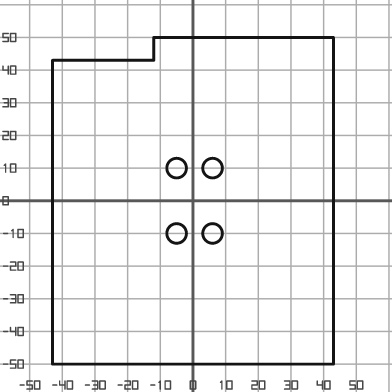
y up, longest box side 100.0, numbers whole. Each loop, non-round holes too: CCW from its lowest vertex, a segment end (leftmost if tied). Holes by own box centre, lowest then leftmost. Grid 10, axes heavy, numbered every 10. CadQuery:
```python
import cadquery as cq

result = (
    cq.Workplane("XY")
    .moveTo(-43.0, -50.0)
    .lineTo(43.0, -50.0)
    .lineTo(43.0, 50.0)
    .lineTo(-12.0, 50.0)
    .lineTo(-12.0, 43.0)
    .lineTo(-43.0, 43.0)
    .close()
    .moveTo(-5.0, -10.0)
    .circle(3.0)
    .moveTo(6.0, -10.0)
    .circle(3.0)
    .moveTo(-5.0, 10.0)
    .circle(3.0)
    .moveTo(6.0, 10.0)
    .circle(3.0)
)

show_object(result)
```